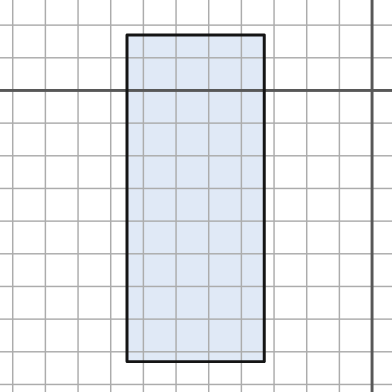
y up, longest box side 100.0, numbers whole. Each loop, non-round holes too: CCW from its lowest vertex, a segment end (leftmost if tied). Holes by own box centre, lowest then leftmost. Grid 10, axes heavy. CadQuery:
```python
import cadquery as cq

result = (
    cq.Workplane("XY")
    .moveTo(-75.0, -83.0)
    .lineTo(-33.0, -83.0)
    .lineTo(-33.0, 17.0)
    .lineTo(-75.0, 17.0)
    .close()
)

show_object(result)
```